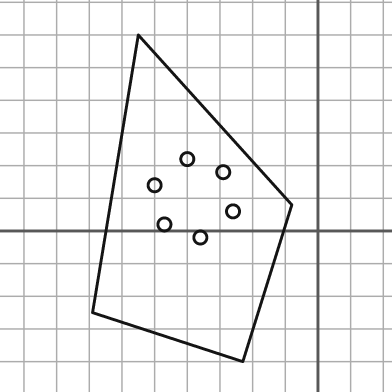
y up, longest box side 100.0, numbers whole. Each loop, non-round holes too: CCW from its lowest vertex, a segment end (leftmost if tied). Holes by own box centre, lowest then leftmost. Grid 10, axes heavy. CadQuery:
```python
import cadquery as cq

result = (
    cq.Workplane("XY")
    .moveTo(-23.0, -40.0)
    .lineTo(-8.0, 8.0)
    .lineTo(-55.0, 60.0)
    .lineTo(-69.0, -25.0)
    .close()
    .moveTo(-36.0, -2.0)
    .circle(2.0)
    .moveTo(-47.0, 2.0)
    .circle(2.0)
    .moveTo(-26.0, 6.0)
    .circle(2.0)
    .moveTo(-50.0, 14.0)
    .circle(2.0)
    .moveTo(-29.0, 18.0)
    .circle(2.0)
    .moveTo(-40.0, 22.0)
    .circle(2.0)
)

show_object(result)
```